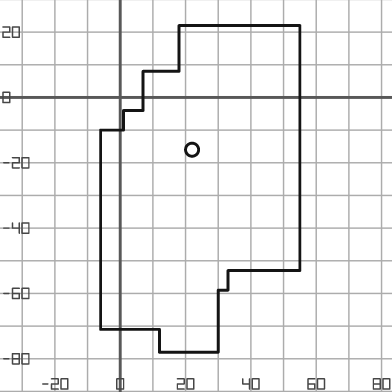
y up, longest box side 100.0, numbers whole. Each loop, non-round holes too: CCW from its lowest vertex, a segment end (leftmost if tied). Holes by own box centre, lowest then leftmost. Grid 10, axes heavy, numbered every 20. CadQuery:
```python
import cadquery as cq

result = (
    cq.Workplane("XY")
    .moveTo(12.0, -78.0)
    .lineTo(30.0, -78.0)
    .lineTo(30.0, -59.0)
    .lineTo(33.0, -59.0)
    .lineTo(33.0, -53.0)
    .lineTo(55.0, -53.0)
    .lineTo(55.0, 22.0)
    .lineTo(18.0, 22.0)
    .lineTo(18.0, 8.0)
    .lineTo(7.0, 8.0)
    .lineTo(7.0, -4.0)
    .lineTo(1.0, -4.0)
    .lineTo(1.0, -10.0)
    .lineTo(-6.0, -10.0)
    .lineTo(-6.0, -71.0)
    .lineTo(12.0, -71.0)
    .close()
    .moveTo(22.0, -16.0)
    .circle(2.0)
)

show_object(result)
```